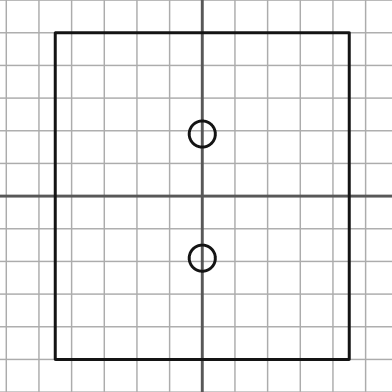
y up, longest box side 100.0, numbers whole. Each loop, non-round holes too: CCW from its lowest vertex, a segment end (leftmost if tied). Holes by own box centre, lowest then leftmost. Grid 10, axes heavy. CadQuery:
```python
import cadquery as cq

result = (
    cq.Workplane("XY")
    .moveTo(-45.0, -50.0)
    .lineTo(45.0, -50.0)
    .lineTo(45.0, 50.0)
    .lineTo(-45.0, 50.0)
    .close()
    .moveTo(0.0, -19.0)
    .circle(4.0)
    .moveTo(0.0, 19.0)
    .circle(4.0)
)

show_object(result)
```